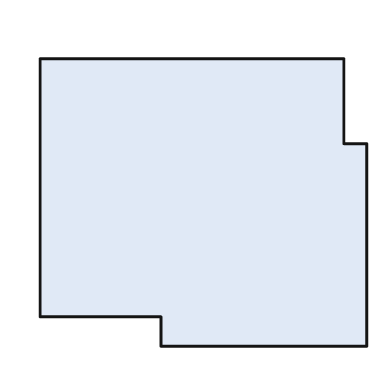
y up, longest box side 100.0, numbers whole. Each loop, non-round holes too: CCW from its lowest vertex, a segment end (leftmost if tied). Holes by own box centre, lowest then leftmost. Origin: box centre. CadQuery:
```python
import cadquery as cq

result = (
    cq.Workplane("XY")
    .moveTo(-13.0, -44.0)
    .lineTo(50.0, -44.0)
    .lineTo(50.0, 18.0)
    .lineTo(43.0, 18.0)
    .lineTo(43.0, 44.0)
    .lineTo(-50.0, 44.0)
    .lineTo(-50.0, -35.0)
    .lineTo(-13.0, -35.0)
    .close()
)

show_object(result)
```